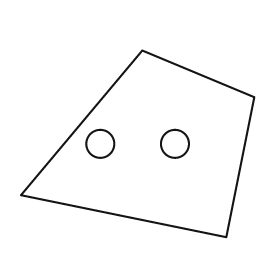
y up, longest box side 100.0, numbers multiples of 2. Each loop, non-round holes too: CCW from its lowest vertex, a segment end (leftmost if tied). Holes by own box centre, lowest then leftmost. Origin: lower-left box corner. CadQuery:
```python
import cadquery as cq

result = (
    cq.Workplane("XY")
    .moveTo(88.0, 0.0)
    .lineTo(100.0, 60.0)
    .lineTo(52.0, 80.0)
    .lineTo(0.0, 18.0)
    .close()
    .moveTo(34.0, 40.0)
    .circle(6.0)
    .moveTo(66.0, 40.0)
    .circle(6.0)
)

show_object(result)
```